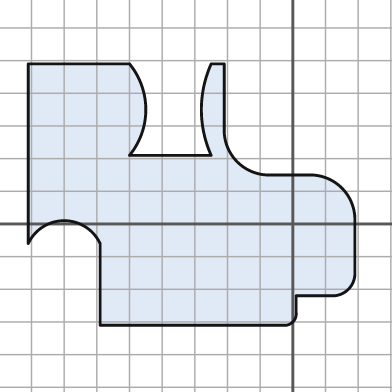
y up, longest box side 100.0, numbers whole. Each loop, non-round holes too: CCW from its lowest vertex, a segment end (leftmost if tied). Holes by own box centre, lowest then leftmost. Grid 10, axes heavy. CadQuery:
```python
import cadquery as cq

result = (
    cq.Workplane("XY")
    .moveTo(-59.0, -31.0)
    .lineTo(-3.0, -31.0)
    .threePointArc((0.0, -30.0), (1.0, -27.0))
    .lineTo(1.0, -22.0)
    .lineTo(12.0, -22.0)
    .threePointArc((17.0, -20.0), (19.0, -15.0))
    .lineTo(19.0, 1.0)
    .threePointArc((15.0, 11.0), (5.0, 15.0))
    .lineTo(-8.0, 15.0)
    .threePointArc((-17.0, 19.0), (-21.0, 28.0))
    .lineTo(-21.0, 49.0)
    .lineTo(-25.0, 49.0)
    .threePointArc((-28.0, 35.0), (-25.0, 21.0))
    .lineTo(-50.0, 21.0)
    .threePointArc((-45.0, 35.0), (-50.0, 49.0))
    .lineTo(-81.0, 49.0)
    .lineTo(-81.0, -6.0)
    .threePointArc((-70.0, 1.0), (-59.0, -6.0))
    .close()
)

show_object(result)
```